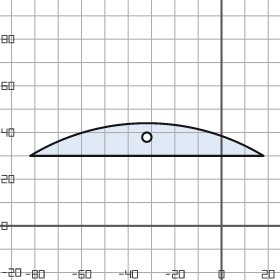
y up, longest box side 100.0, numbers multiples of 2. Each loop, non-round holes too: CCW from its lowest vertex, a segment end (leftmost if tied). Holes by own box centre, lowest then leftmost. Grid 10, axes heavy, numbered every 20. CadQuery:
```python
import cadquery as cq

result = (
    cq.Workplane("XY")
    .moveTo(-82.0, 30.0)
    .lineTo(18.0, 30.0)
    .threePointArc((-32.0, 44.0), (-82.0, 30.0))
    .close()
    .moveTo(-32.0, 38.0)
    .circle(2.0)
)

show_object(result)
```